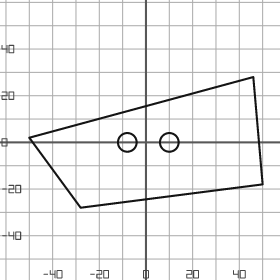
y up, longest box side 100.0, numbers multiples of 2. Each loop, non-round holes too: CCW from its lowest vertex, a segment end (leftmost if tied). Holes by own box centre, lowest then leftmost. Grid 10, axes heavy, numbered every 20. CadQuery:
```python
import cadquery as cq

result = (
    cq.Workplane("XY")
    .moveTo(-28.0, -28.0)
    .lineTo(50.0, -18.0)
    .lineTo(46.0, 28.0)
    .lineTo(-50.0, 2.0)
    .close()
    .moveTo(-8.0, 0.0)
    .circle(4.0)
    .moveTo(10.0, 0.0)
    .circle(4.0)
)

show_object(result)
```